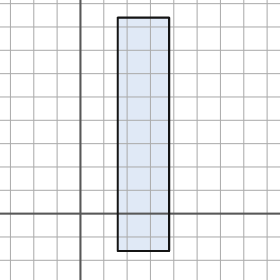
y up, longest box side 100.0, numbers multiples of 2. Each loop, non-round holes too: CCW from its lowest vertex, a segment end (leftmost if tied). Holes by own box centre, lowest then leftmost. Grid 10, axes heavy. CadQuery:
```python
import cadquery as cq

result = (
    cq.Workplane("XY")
    .moveTo(16.0, -16.0)
    .lineTo(38.0, -16.0)
    .lineTo(38.0, 84.0)
    .lineTo(16.0, 84.0)
    .close()
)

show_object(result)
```